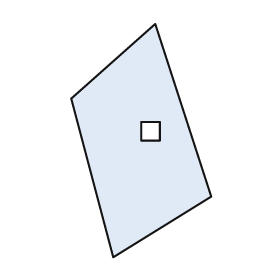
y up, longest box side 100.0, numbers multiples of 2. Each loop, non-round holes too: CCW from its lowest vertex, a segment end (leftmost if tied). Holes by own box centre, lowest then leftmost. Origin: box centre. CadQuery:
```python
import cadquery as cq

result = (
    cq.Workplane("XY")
    .moveTo(-12.0, -50.0)
    .lineTo(30.0, -24.0)
    .lineTo(6.0, 50.0)
    .lineTo(-30.0, 18.0)
    .close()
    .moveTo(0.0, 0.0)
    .lineTo(8.0, 0.0)
    .lineTo(8.0, 8.0)
    .lineTo(0.0, 8.0)
    .close()
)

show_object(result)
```